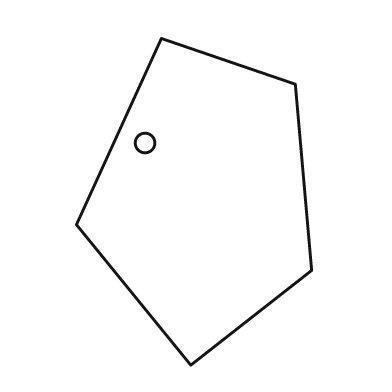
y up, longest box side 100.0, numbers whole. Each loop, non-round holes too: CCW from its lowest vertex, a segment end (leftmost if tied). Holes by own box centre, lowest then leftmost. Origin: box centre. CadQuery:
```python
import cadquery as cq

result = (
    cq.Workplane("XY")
    .moveTo(-1.0, -50.0)
    .lineTo(36.0, -21.0)
    .lineTo(31.0, 36.0)
    .lineTo(-10.0, 50.0)
    .lineTo(-36.0, -7.0)
    .close()
    .moveTo(-15.0, 18.0)
    .circle(3.0)
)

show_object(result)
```